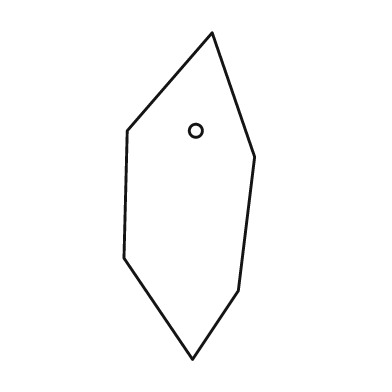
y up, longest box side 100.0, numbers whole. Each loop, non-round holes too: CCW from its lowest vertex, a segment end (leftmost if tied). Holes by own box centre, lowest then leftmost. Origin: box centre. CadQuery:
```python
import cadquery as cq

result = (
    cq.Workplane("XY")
    .moveTo(1.0, -50.0)
    .lineTo(15.0, -29.0)
    .lineTo(20.0, 12.0)
    .lineTo(7.0, 50.0)
    .lineTo(-19.0, 20.0)
    .lineTo(-20.0, -19.0)
    .close()
    .moveTo(2.0, 20.0)
    .circle(2.0)
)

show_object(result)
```